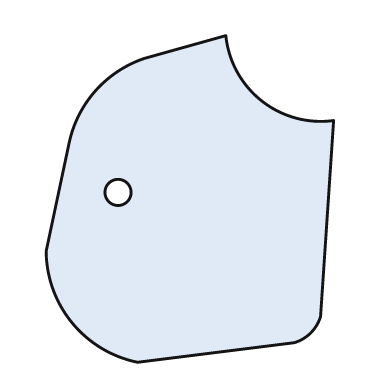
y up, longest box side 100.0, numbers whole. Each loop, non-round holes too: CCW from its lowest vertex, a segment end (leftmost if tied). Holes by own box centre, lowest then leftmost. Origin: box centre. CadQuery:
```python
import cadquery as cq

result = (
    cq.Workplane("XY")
    .moveTo(-16.0, -50.0)
    .lineTo(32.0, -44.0)
    .threePointArc((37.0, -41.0), (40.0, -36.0))
    .lineTo(44.0, 24.0)
    .threePointArc((22.0, 30.0), (11.0, 50.0))
    .lineTo(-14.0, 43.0)
    .threePointArc((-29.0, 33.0), (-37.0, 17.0))
    .lineTo(-44.0, -16.0)
    .threePointArc((-36.0, -38.0), (-16.0, -50.0))
    .close()
    .moveTo(-22.0, 2.0)
    .circle(4.0)
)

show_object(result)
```